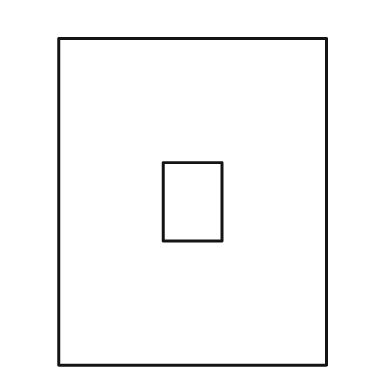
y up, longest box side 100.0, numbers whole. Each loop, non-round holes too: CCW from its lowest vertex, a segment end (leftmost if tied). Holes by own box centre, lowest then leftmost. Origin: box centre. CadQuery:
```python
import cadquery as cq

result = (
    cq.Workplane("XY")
    .moveTo(-41.0, -50.0)
    .lineTo(41.0, -50.0)
    .lineTo(41.0, 50.0)
    .lineTo(-41.0, 50.0)
    .close()
    .moveTo(-9.0, -12.0)
    .lineTo(9.0, -12.0)
    .lineTo(9.0, 12.0)
    .lineTo(-9.0, 12.0)
    .close()
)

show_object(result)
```